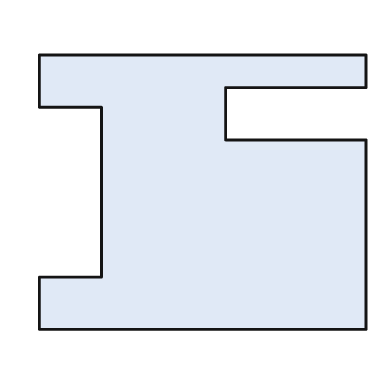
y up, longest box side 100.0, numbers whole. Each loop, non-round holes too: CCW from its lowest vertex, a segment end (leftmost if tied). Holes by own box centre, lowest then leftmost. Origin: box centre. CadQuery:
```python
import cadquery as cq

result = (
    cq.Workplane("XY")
    .moveTo(-50.0, -42.0)
    .lineTo(50.0, -42.0)
    .lineTo(50.0, 16.0)
    .lineTo(7.0, 16.0)
    .lineTo(7.0, 32.0)
    .lineTo(50.0, 32.0)
    .lineTo(50.0, 42.0)
    .lineTo(-50.0, 42.0)
    .lineTo(-50.0, 26.0)
    .lineTo(-31.0, 26.0)
    .lineTo(-31.0, -26.0)
    .lineTo(-50.0, -26.0)
    .close()
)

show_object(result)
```